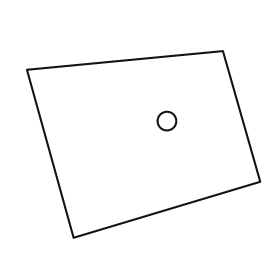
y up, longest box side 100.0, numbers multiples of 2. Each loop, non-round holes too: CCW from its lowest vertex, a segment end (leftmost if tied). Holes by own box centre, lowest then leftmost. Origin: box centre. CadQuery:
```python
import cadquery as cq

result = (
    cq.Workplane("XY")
    .moveTo(-30.0, -40.0)
    .lineTo(50.0, -16.0)
    .lineTo(34.0, 40.0)
    .lineTo(-50.0, 32.0)
    .close()
    .moveTo(10.0, 10.0)
    .circle(4.0)
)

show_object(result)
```